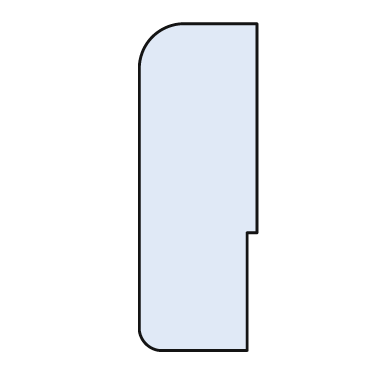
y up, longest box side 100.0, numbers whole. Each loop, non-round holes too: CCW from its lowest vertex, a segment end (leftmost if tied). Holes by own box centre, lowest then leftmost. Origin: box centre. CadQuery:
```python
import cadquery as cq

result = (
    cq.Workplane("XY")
    .moveTo(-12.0, -50.0)
    .lineTo(15.0, -50.0)
    .lineTo(15.0, -14.0)
    .lineTo(18.0, -14.0)
    .lineTo(18.0, 50.0)
    .lineTo(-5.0, 50.0)
    .threePointArc((-14.0, 46.0), (-18.0, 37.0))
    .lineTo(-18.0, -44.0)
    .threePointArc((-16.0, -48.0), (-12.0, -50.0))
    .close()
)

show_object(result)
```